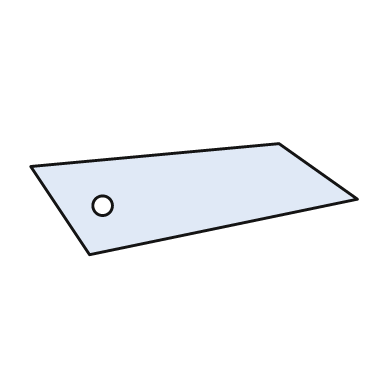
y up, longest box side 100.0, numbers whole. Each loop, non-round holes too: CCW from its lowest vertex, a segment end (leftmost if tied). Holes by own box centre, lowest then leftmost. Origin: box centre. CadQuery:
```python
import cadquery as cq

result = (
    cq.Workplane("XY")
    .moveTo(-32.0, -17.0)
    .lineTo(50.0, 0.0)
    .lineTo(26.0, 17.0)
    .lineTo(-50.0, 10.0)
    .close()
    .moveTo(-28.0, -2.0)
    .circle(3.0)
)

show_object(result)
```